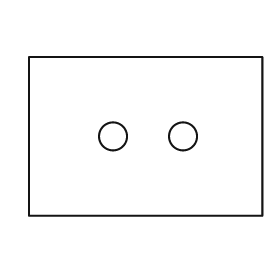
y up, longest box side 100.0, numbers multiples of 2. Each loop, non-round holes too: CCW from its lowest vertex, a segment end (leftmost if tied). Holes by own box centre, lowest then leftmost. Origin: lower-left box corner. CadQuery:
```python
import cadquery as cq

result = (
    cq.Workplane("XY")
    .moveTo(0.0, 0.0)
    .lineTo(100.0, 0.0)
    .lineTo(100.0, 68.0)
    .lineTo(0.0, 68.0)
    .close()
    .moveTo(36.0, 34.0)
    .circle(6.0)
    .moveTo(66.0, 34.0)
    .circle(6.0)
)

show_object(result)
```